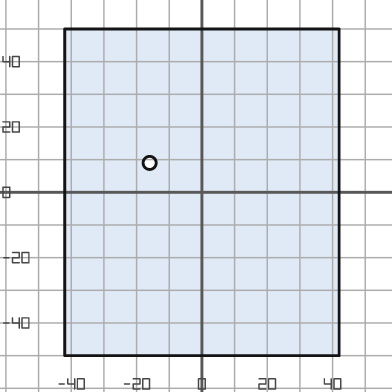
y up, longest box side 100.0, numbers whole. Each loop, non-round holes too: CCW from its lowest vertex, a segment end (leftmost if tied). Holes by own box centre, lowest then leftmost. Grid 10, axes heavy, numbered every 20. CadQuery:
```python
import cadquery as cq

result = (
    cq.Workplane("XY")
    .moveTo(-42.0, -50.0)
    .lineTo(42.0, -50.0)
    .lineTo(42.0, 50.0)
    .lineTo(-42.0, 50.0)
    .close()
    .moveTo(-16.0, 9.0)
    .circle(2.0)
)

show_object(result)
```